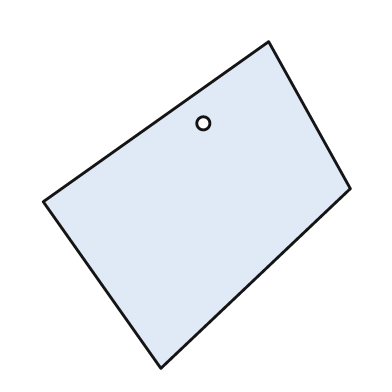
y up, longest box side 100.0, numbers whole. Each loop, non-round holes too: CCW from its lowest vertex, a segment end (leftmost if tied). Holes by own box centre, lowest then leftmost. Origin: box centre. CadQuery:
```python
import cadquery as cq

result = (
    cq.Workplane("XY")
    .moveTo(-11.0, -50.0)
    .lineTo(47.0, 5.0)
    .lineTo(22.0, 50.0)
    .lineTo(-47.0, 1.0)
    .close()
    .moveTo(2.0, 25.0)
    .circle(2.0)
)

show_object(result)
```